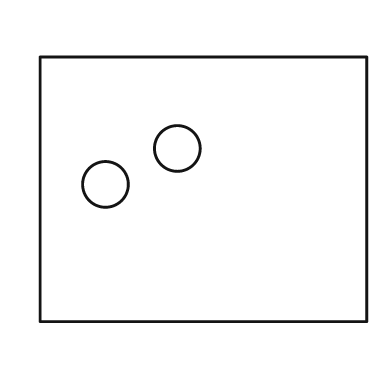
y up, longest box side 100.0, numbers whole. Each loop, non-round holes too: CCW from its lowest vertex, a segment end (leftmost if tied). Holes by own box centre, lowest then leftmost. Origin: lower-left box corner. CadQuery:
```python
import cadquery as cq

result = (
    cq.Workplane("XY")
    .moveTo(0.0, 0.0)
    .lineTo(100.0, 0.0)
    .lineTo(100.0, 81.0)
    .lineTo(0.0, 81.0)
    .close()
    .moveTo(20.0, 42.0)
    .circle(7.0)
    .moveTo(42.0, 53.0)
    .circle(7.0)
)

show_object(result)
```